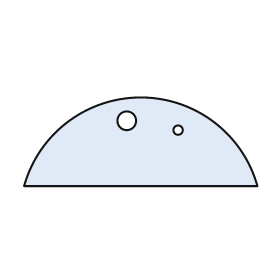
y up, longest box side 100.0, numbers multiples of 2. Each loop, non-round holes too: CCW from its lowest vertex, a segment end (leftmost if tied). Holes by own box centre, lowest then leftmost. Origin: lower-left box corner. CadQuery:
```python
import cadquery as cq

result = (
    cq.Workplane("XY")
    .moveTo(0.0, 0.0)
    .lineTo(100.0, 0.0)
    .threePointArc((50.0, 38.0), (0.0, 0.0))
    .close()
    .moveTo(66.0, 24.0)
    .circle(2.0)
    .moveTo(44.0, 28.0)
    .circle(4.0)
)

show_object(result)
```